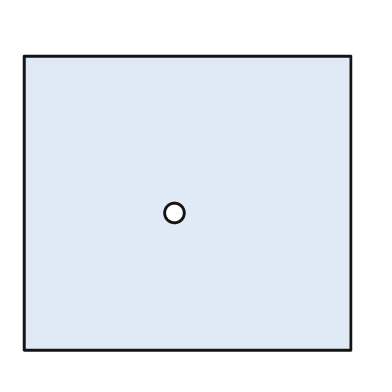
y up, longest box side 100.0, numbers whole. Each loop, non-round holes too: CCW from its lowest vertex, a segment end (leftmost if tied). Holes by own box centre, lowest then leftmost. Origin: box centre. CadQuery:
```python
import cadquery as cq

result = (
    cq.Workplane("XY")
    .moveTo(-50.0, -45.0)
    .lineTo(50.0, -45.0)
    .lineTo(50.0, 45.0)
    .lineTo(-50.0, 45.0)
    .close()
    .moveTo(-4.0, -3.0)
    .circle(3.0)
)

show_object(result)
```